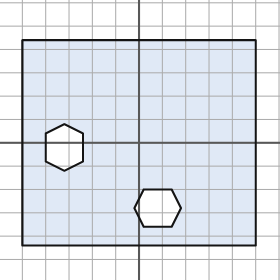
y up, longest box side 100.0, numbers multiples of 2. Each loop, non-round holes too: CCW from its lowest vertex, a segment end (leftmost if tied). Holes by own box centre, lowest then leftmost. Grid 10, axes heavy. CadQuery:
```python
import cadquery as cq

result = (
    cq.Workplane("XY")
    .moveTo(-50.0, -44.0)
    .lineTo(50.0, -44.0)
    .lineTo(50.0, 44.0)
    .lineTo(-50.0, 44.0)
    .close()
    .moveTo(2.0, -36.0)
    .lineTo(14.0, -36.0)
    .lineTo(18.0, -28.0)
    .lineTo(14.0, -20.0)
    .lineTo(2.0, -20.0)
    .lineTo(-2.0, -28.0)
    .close()
    .moveTo(-32.0, -12.0)
    .lineTo(-24.0, -8.0)
    .lineTo(-24.0, 4.0)
    .lineTo(-32.0, 8.0)
    .lineTo(-40.0, 4.0)
    .lineTo(-40.0, -8.0)
    .close()
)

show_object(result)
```